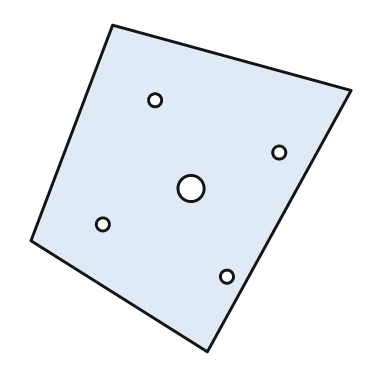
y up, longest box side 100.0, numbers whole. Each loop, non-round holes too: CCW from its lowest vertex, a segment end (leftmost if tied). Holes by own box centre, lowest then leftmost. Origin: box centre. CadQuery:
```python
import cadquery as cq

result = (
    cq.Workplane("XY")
    .moveTo(5.0, -50.0)
    .lineTo(49.0, 30.0)
    .lineTo(-24.0, 50.0)
    .lineTo(-49.0, -16.0)
    .close()
    .moveTo(11.0, -27.0)
    .circle(2.0)
    .moveTo(-27.0, -11.0)
    .circle(2.0)
    .moveTo(0.0, 0.0)
    .circle(4.0)
    .moveTo(27.0, 11.0)
    .circle(2.0)
    .moveTo(-11.0, 27.0)
    .circle(2.0)
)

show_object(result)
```